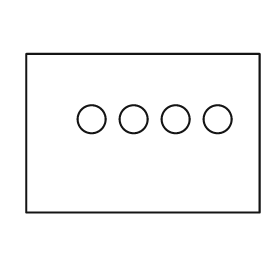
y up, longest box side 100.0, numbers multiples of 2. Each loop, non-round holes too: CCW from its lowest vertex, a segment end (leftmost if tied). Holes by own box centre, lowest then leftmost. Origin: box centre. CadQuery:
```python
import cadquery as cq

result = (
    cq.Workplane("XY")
    .moveTo(-50.0, -34.0)
    .lineTo(50.0, -34.0)
    .lineTo(50.0, 34.0)
    .lineTo(-50.0, 34.0)
    .close()
    .moveTo(-22.0, 6.0)
    .circle(6.0)
    .moveTo(-4.0, 6.0)
    .circle(6.0)
    .moveTo(14.0, 6.0)
    .circle(6.0)
    .moveTo(32.0, 6.0)
    .circle(6.0)
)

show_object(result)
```